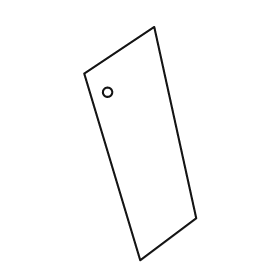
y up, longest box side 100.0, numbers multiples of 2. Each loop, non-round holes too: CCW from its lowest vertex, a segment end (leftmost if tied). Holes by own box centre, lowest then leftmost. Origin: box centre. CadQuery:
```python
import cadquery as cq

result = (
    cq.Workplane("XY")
    .moveTo(0.0, -50.0)
    .lineTo(24.0, -32.0)
    .lineTo(6.0, 50.0)
    .lineTo(-24.0, 30.0)
    .close()
    .moveTo(-14.0, 22.0)
    .circle(2.0)
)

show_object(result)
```